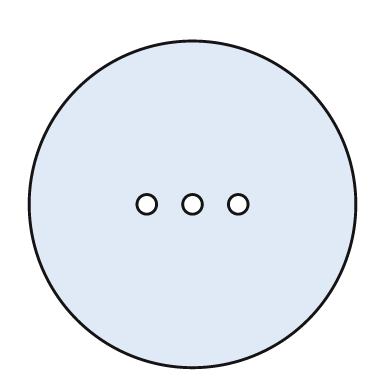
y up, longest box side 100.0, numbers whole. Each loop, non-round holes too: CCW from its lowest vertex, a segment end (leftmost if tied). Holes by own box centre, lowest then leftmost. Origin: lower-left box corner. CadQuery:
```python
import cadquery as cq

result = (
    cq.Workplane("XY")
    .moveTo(50.0, 50.0)
    .circle(50.0)
    .moveTo(36.0, 50.0)
    .circle(3.0)
    .moveTo(50.0, 50.0)
    .circle(3.0)
    .moveTo(64.0, 50.0)
    .circle(3.0)
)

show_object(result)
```